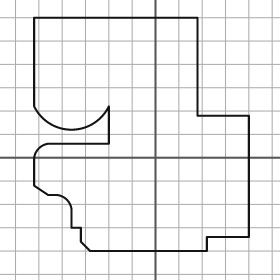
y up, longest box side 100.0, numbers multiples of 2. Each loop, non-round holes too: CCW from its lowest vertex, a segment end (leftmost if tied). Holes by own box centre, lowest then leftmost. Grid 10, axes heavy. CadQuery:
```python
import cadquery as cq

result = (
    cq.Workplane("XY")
    .moveTo(-28.0, -40.0)
    .lineTo(22.0, -40.0)
    .lineTo(22.0, -34.0)
    .lineTo(40.0, -34.0)
    .lineTo(40.0, 18.0)
    .lineTo(18.0, 18.0)
    .lineTo(18.0, 60.0)
    .lineTo(-52.0, 60.0)
    .lineTo(-52.0, 22.0)
    .threePointArc((-36.0, 12.0), (-20.0, 22.0))
    .lineTo(-20.0, 6.0)
    .lineTo(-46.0, 6.0)
    .threePointArc((-50.0, 4.0), (-52.0, 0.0))
    .lineTo(-52.0, -12.0)
    .lineTo(-46.0, -16.0)
    .lineTo(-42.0, -16.0)
    .threePointArc((-38.0, -18.0), (-36.0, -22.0))
    .lineTo(-36.0, -30.0)
    .lineTo(-32.0, -30.0)
    .lineTo(-32.0, -36.0)
    .close()
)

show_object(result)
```